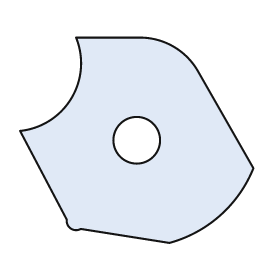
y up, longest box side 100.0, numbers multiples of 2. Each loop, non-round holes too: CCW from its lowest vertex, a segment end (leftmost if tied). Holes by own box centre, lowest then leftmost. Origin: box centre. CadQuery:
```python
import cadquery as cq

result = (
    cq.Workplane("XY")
    .moveTo(14.0, -44.0)
    .threePointArc((36.0, -32.0), (50.0, -12.0))
    .lineTo(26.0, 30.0)
    .threePointArc((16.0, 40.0), (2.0, 44.0))
    .lineTo(-26.0, 44.0)
    .threePointArc((-28.0, 18.0), (-50.0, 4.0))
    .lineTo(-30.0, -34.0)
    .threePointArc((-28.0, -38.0), (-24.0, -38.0))
    .close()
    .moveTo(0.0, 0.0)
    .circle(10.0)
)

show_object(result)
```